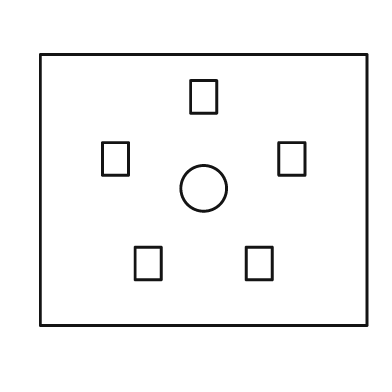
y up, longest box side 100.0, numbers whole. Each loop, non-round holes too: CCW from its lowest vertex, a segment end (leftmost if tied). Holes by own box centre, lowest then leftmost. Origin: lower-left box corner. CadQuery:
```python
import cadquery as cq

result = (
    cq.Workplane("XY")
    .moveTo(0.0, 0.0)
    .lineTo(100.0, 0.0)
    .lineTo(100.0, 83.0)
    .lineTo(0.0, 83.0)
    .close()
    .moveTo(29.0, 14.0)
    .lineTo(37.0, 14.0)
    .lineTo(37.0, 24.0)
    .lineTo(29.0, 24.0)
    .close()
    .moveTo(63.0, 14.0)
    .lineTo(71.0, 14.0)
    .lineTo(71.0, 24.0)
    .lineTo(63.0, 24.0)
    .close()
    .moveTo(50.0, 42.0)
    .circle(7.0)
    .moveTo(19.0, 46.0)
    .lineTo(27.0, 46.0)
    .lineTo(27.0, 56.0)
    .lineTo(19.0, 56.0)
    .close()
    .moveTo(73.0, 46.0)
    .lineTo(81.0, 46.0)
    .lineTo(81.0, 56.0)
    .lineTo(73.0, 56.0)
    .close()
    .moveTo(46.0, 65.0)
    .lineTo(54.0, 65.0)
    .lineTo(54.0, 75.0)
    .lineTo(46.0, 75.0)
    .close()
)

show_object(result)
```